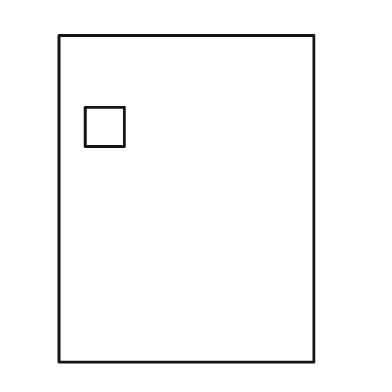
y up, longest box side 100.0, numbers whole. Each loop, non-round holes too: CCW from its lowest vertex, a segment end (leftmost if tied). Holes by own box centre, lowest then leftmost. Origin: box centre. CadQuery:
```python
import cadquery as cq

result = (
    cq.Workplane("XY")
    .moveTo(-39.0, -50.0)
    .lineTo(39.0, -50.0)
    .lineTo(39.0, 50.0)
    .lineTo(-39.0, 50.0)
    .close()
    .moveTo(-31.0, 16.0)
    .lineTo(-19.0, 16.0)
    .lineTo(-19.0, 28.0)
    .lineTo(-31.0, 28.0)
    .close()
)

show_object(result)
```